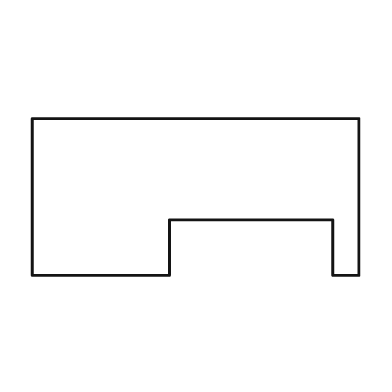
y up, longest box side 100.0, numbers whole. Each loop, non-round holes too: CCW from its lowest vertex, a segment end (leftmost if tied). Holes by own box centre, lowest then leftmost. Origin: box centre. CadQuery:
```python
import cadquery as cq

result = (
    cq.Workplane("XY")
    .moveTo(-50.0, -24.0)
    .lineTo(-8.0, -24.0)
    .lineTo(-8.0, -7.0)
    .lineTo(42.0, -7.0)
    .lineTo(42.0, -24.0)
    .lineTo(50.0, -24.0)
    .lineTo(50.0, 24.0)
    .lineTo(-50.0, 24.0)
    .close()
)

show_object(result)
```